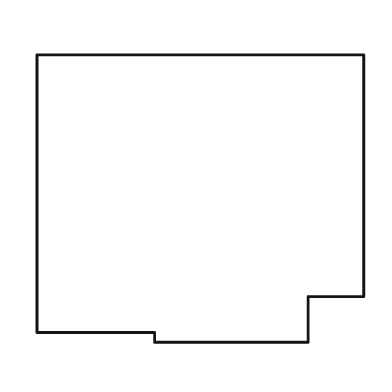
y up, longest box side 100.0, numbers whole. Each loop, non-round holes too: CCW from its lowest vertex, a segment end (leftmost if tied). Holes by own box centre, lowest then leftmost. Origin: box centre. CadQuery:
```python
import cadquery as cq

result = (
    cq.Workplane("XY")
    .moveTo(-14.0, -44.0)
    .lineTo(33.0, -44.0)
    .lineTo(33.0, -30.0)
    .lineTo(50.0, -30.0)
    .lineTo(50.0, 44.0)
    .lineTo(-50.0, 44.0)
    .lineTo(-50.0, -41.0)
    .lineTo(-14.0, -41.0)
    .close()
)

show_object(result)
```